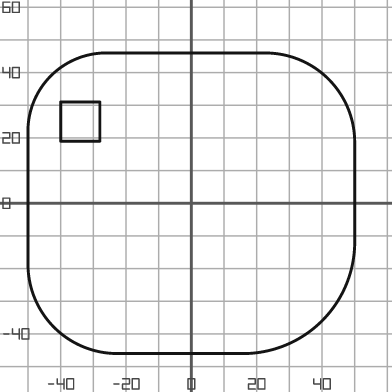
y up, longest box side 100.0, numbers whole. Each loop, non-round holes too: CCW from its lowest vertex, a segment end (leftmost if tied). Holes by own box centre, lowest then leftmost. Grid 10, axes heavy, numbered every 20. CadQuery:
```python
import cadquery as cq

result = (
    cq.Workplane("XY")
    .moveTo(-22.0, -46.0)
    .lineTo(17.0, -46.0)
    .threePointArc((40.0, -36.0), (50.0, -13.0))
    .lineTo(50.0, 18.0)
    .threePointArc((42.0, 38.0), (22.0, 46.0))
    .lineTo(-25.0, 46.0)
    .threePointArc((-43.0, 39.0), (-50.0, 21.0))
    .lineTo(-50.0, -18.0)
    .threePointArc((-42.0, -38.0), (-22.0, -46.0))
    .close()
    .moveTo(-40.0, 19.0)
    .lineTo(-28.0, 19.0)
    .lineTo(-28.0, 31.0)
    .lineTo(-40.0, 31.0)
    .close()
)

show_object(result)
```